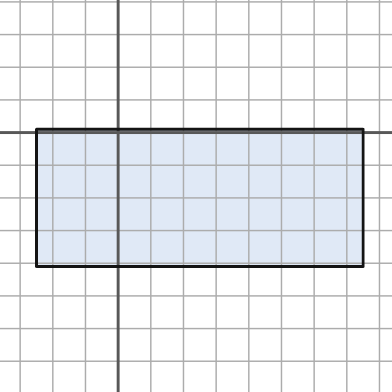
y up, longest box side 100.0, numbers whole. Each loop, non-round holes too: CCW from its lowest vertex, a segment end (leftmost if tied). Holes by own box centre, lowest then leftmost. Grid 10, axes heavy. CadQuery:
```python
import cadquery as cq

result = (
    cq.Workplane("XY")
    .moveTo(-25.0, -41.0)
    .lineTo(75.0, -41.0)
    .lineTo(75.0, 1.0)
    .lineTo(-25.0, 1.0)
    .close()
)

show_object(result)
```